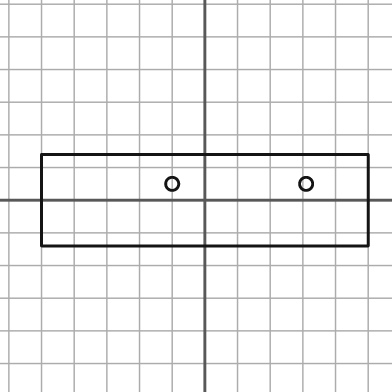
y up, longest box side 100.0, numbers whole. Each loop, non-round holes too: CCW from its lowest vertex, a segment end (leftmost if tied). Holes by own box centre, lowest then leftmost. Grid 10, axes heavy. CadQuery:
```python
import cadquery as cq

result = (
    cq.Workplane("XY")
    .moveTo(-50.0, -14.0)
    .lineTo(50.0, -14.0)
    .lineTo(50.0, 14.0)
    .lineTo(-50.0, 14.0)
    .close()
    .moveTo(-10.0, 5.0)
    .circle(2.0)
    .moveTo(31.0, 5.0)
    .circle(2.0)
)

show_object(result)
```